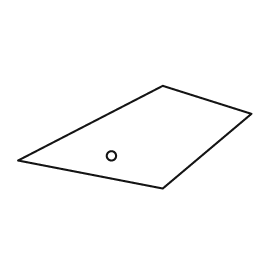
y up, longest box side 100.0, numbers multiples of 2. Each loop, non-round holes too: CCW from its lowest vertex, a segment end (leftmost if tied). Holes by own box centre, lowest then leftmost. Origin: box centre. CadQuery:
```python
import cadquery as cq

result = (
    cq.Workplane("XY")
    .moveTo(12.0, -22.0)
    .lineTo(50.0, 10.0)
    .lineTo(12.0, 22.0)
    .lineTo(-50.0, -10.0)
    .close()
    .moveTo(-10.0, -8.0)
    .circle(2.0)
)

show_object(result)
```